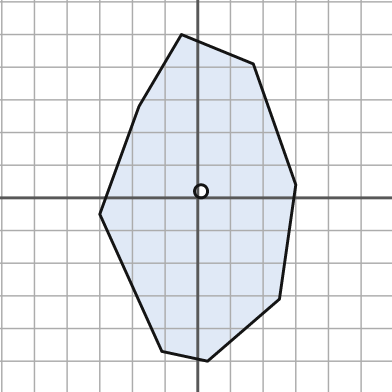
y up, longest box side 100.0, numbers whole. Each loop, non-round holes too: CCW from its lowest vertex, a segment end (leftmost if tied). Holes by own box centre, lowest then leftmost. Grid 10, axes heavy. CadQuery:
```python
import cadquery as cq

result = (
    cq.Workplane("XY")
    .moveTo(3.0, -50.0)
    .lineTo(25.0, -31.0)
    .lineTo(30.0, 4.0)
    .lineTo(17.0, 41.0)
    .lineTo(-5.0, 50.0)
    .lineTo(-18.0, 28.0)
    .lineTo(-30.0, -5.0)
    .lineTo(-11.0, -47.0)
    .close()
    .moveTo(1.0, 2.0)
    .circle(2.0)
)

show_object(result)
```